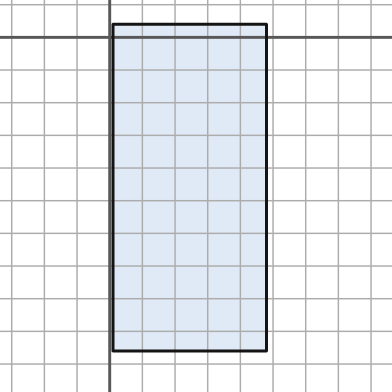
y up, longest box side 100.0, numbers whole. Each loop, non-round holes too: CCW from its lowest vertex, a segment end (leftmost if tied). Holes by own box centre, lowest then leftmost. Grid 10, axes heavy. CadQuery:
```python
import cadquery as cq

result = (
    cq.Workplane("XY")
    .moveTo(1.0, -96.0)
    .lineTo(48.0, -96.0)
    .lineTo(48.0, 4.0)
    .lineTo(1.0, 4.0)
    .close()
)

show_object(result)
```